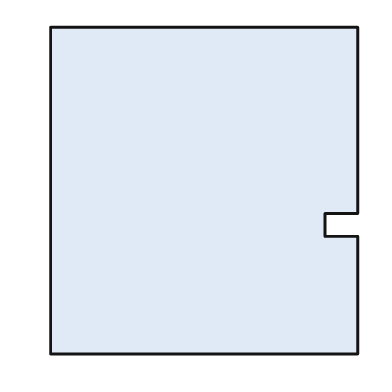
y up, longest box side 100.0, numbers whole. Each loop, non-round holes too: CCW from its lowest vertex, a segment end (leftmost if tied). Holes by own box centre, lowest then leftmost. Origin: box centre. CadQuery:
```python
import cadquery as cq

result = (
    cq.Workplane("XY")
    .moveTo(-47.0, -50.0)
    .lineTo(47.0, -50.0)
    .lineTo(47.0, -14.0)
    .lineTo(37.0, -14.0)
    .lineTo(37.0, -7.0)
    .lineTo(47.0, -7.0)
    .lineTo(47.0, 50.0)
    .lineTo(-47.0, 50.0)
    .close()
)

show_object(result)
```